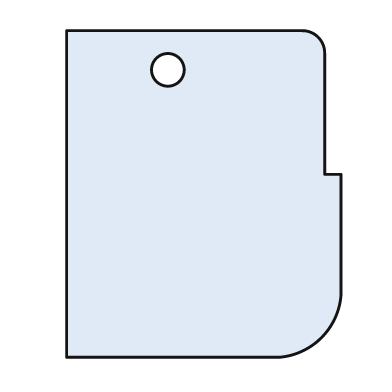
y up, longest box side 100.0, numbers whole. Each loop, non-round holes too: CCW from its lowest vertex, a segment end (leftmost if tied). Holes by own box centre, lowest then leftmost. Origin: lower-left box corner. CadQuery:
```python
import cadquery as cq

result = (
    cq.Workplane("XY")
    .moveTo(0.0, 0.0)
    .lineTo(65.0, 0.0)
    .threePointArc((78.0, 6.0), (84.0, 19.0))
    .lineTo(84.0, 56.0)
    .lineTo(79.0, 56.0)
    .lineTo(79.0, 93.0)
    .threePointArc((77.0, 98.0), (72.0, 100.0))
    .lineTo(0.0, 100.0)
    .close()
    .moveTo(31.0, 88.0)
    .circle(5.0)
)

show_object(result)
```